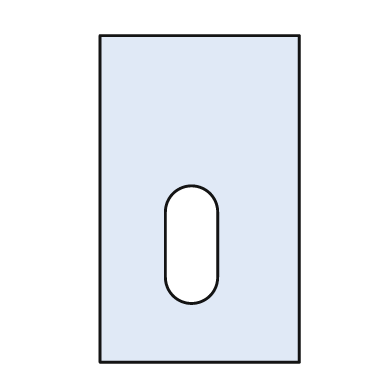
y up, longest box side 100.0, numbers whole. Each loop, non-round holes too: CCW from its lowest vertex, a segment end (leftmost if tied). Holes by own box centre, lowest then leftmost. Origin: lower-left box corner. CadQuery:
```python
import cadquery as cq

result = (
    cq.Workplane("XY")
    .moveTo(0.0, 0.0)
    .lineTo(61.0, 0.0)
    .lineTo(61.0, 100.0)
    .lineTo(0.0, 100.0)
    .close()
    .moveTo(20.0, 26.0)
    .threePointArc((28.0, 18.0), (36.0, 26.0))
    .lineTo(36.0, 46.0)
    .threePointArc((28.0, 54.0), (20.0, 46.0))
    .close()
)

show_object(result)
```